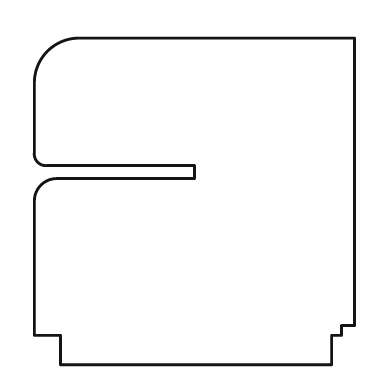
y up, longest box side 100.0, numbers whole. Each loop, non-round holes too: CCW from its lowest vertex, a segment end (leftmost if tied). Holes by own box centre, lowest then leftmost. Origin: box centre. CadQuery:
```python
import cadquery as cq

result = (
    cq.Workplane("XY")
    .moveTo(-41.0, -50.0)
    .lineTo(42.0, -50.0)
    .lineTo(42.0, -41.0)
    .lineTo(45.0, -41.0)
    .lineTo(45.0, -38.0)
    .lineTo(49.0, -38.0)
    .lineTo(49.0, 50.0)
    .lineTo(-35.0, 50.0)
    .threePointArc((-45.0, 46.0), (-49.0, 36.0))
    .lineTo(-49.0, 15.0)
    .threePointArc((-48.0, 12.0), (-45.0, 11.0))
    .lineTo(0.0, 11.0)
    .lineTo(0.0, 7.0)
    .lineTo(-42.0, 7.0)
    .threePointArc((-47.0, 5.0), (-49.0, 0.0))
    .lineTo(-49.0, -41.0)
    .lineTo(-41.0, -41.0)
    .close()
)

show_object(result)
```